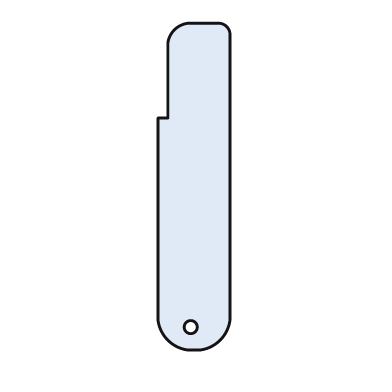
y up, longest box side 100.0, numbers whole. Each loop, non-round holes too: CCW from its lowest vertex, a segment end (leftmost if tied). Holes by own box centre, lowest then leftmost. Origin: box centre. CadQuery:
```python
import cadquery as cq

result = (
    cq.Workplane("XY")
    .moveTo(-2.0, -50.0)
    .lineTo(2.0, -50.0)
    .threePointArc((8.0, -47.0), (11.0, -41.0))
    .lineTo(11.0, 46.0)
    .threePointArc((10.0, 49.0), (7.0, 50.0))
    .lineTo(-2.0, 50.0)
    .threePointArc((-6.0, 48.0), (-8.0, 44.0))
    .lineTo(-8.0, 21.0)
    .lineTo(-11.0, 21.0)
    .lineTo(-11.0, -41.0)
    .threePointArc((-8.0, -47.0), (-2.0, -50.0))
    .close()
    .moveTo(-1.0, -43.0)
    .circle(2.0)
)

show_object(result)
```